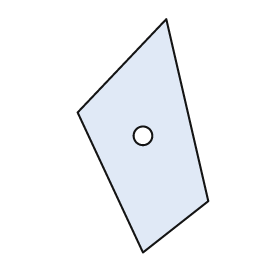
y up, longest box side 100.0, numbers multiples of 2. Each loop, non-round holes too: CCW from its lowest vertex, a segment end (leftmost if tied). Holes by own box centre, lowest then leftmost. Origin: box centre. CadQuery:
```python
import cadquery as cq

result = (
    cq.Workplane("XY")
    .moveTo(0.0, -50.0)
    .lineTo(28.0, -28.0)
    .lineTo(10.0, 50.0)
    .lineTo(-28.0, 10.0)
    .close()
    .moveTo(0.0, 0.0)
    .circle(4.0)
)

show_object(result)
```